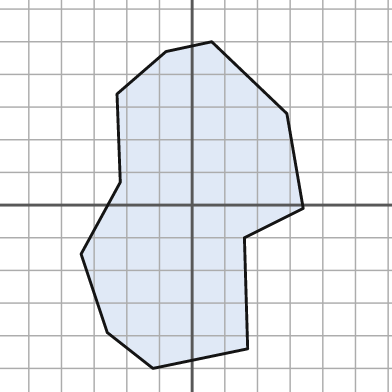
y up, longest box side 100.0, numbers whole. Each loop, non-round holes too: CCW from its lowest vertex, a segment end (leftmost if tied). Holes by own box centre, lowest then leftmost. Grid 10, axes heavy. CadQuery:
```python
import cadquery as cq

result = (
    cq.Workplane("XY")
    .moveTo(-12.0, -50.0)
    .lineTo(17.0, -44.0)
    .lineTo(16.0, -10.0)
    .lineTo(34.0, -1.0)
    .lineTo(29.0, 28.0)
    .lineTo(6.0, 50.0)
    .lineTo(-8.0, 47.0)
    .lineTo(-23.0, 34.0)
    .lineTo(-22.0, 7.0)
    .lineTo(-34.0, -15.0)
    .lineTo(-26.0, -39.0)
    .close()
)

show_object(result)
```